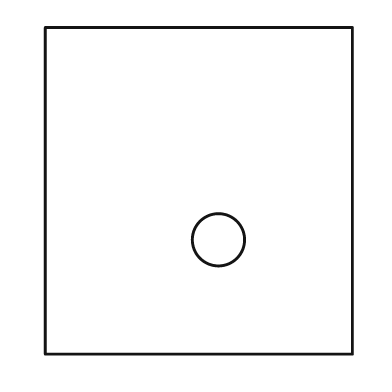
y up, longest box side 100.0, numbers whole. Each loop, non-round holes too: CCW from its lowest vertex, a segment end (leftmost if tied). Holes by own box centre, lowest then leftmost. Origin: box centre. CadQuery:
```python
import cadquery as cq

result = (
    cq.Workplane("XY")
    .moveTo(-47.0, -50.0)
    .lineTo(47.0, -50.0)
    .lineTo(47.0, 50.0)
    .lineTo(-47.0, 50.0)
    .close()
    .moveTo(6.0, -15.0)
    .circle(8.0)
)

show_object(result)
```